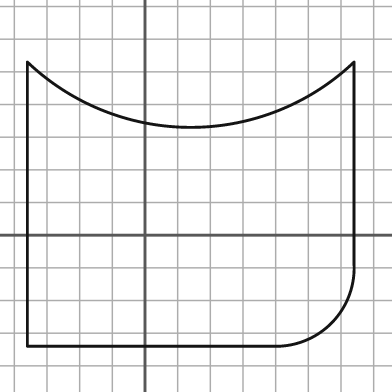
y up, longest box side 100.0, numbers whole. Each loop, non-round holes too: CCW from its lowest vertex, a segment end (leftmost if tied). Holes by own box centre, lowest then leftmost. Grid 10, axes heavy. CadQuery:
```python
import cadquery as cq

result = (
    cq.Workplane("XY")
    .moveTo(-36.0, -34.0)
    .lineTo(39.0, -34.0)
    .threePointArc((57.0, -27.0), (64.0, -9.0))
    .lineTo(64.0, 53.0)
    .threePointArc((14.0, 33.0), (-36.0, 53.0))
    .close()
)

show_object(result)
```